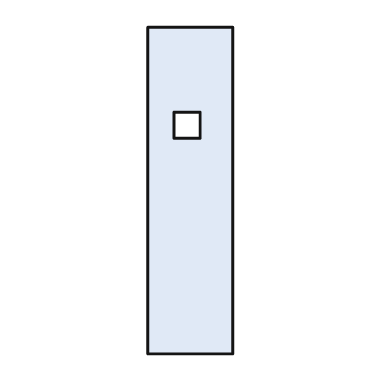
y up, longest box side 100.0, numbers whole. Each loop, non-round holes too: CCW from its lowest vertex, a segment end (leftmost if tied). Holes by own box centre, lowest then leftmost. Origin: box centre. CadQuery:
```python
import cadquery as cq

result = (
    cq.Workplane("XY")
    .moveTo(-13.0, -50.0)
    .lineTo(13.0, -50.0)
    .lineTo(13.0, 50.0)
    .lineTo(-13.0, 50.0)
    .close()
    .moveTo(-5.0, 16.0)
    .lineTo(3.0, 16.0)
    .lineTo(3.0, 24.0)
    .lineTo(-5.0, 24.0)
    .close()
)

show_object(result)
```